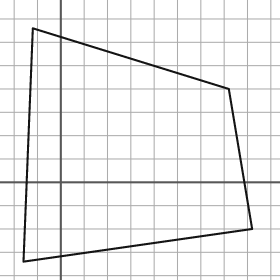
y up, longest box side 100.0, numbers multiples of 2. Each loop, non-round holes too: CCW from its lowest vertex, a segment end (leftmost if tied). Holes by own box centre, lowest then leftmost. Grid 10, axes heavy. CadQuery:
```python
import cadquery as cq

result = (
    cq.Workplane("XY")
    .moveTo(-16.0, -34.0)
    .lineTo(82.0, -20.0)
    .lineTo(72.0, 40.0)
    .lineTo(-12.0, 66.0)
    .close()
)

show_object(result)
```